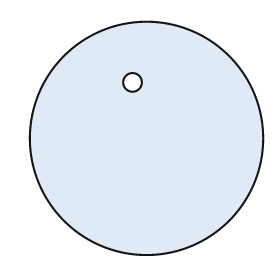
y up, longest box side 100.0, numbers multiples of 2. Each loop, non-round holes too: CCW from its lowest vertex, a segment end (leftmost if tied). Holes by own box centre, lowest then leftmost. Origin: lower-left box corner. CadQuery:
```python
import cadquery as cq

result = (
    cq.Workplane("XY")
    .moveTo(50.0, 50.0)
    .circle(50.0)
    .moveTo(44.0, 74.0)
    .circle(4.0)
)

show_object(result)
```